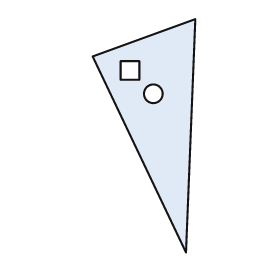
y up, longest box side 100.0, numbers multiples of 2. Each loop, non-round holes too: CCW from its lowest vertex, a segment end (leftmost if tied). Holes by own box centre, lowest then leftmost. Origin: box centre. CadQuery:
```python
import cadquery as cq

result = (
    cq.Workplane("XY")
    .moveTo(18.0, -50.0)
    .lineTo(22.0, 50.0)
    .lineTo(-22.0, 34.0)
    .close()
    .moveTo(4.0, 18.0)
    .circle(4.0)
    .moveTo(-10.0, 24.0)
    .lineTo(-2.0, 24.0)
    .lineTo(-2.0, 32.0)
    .lineTo(-10.0, 32.0)
    .close()
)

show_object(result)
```